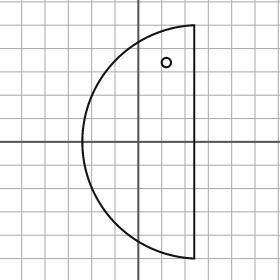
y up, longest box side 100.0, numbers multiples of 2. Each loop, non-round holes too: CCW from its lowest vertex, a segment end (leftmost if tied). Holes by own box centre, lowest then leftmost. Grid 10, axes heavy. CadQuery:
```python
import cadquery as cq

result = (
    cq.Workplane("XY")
    .moveTo(24.0, -50.0)
    .lineTo(24.0, 50.0)
    .threePointArc((-24.0, 0.0), (24.0, -50.0))
    .close()
    .moveTo(12.0, 34.0)
    .circle(2.0)
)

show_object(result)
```